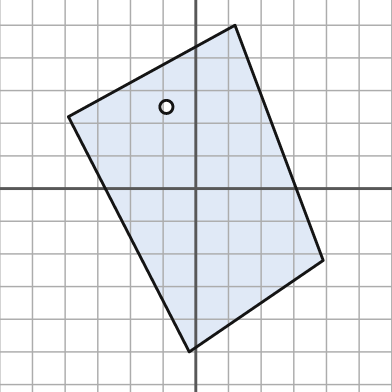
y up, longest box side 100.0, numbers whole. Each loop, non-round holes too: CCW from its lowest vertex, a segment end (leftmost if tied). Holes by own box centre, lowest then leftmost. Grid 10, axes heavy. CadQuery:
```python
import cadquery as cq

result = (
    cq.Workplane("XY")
    .moveTo(-2.0, -50.0)
    .lineTo(39.0, -22.0)
    .lineTo(12.0, 50.0)
    .lineTo(-39.0, 22.0)
    .close()
    .moveTo(-9.0, 25.0)
    .circle(2.0)
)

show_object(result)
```